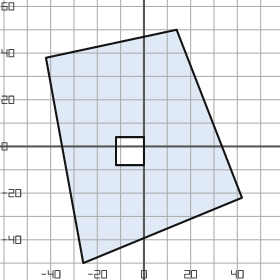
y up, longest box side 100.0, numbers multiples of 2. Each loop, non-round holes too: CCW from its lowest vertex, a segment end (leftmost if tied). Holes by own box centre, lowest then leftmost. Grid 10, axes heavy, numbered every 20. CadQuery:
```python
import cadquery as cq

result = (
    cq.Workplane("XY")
    .moveTo(-26.0, -50.0)
    .lineTo(42.0, -22.0)
    .lineTo(14.0, 50.0)
    .lineTo(-42.0, 38.0)
    .close()
    .moveTo(-12.0, -8.0)
    .lineTo(0.0, -8.0)
    .lineTo(0.0, 4.0)
    .lineTo(-12.0, 4.0)
    .close()
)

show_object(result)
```